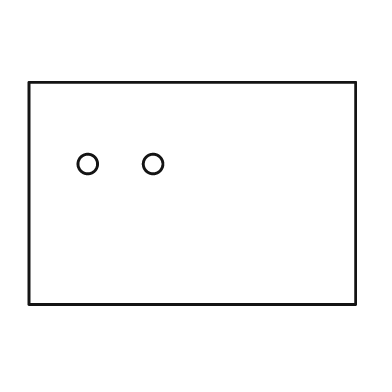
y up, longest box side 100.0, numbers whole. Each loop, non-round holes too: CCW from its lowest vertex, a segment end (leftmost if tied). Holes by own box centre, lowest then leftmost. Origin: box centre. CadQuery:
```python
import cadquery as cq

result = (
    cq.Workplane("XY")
    .moveTo(-50.0, -34.0)
    .lineTo(50.0, -34.0)
    .lineTo(50.0, 34.0)
    .lineTo(-50.0, 34.0)
    .close()
    .moveTo(-32.0, 9.0)
    .circle(3.0)
    .moveTo(-12.0, 9.0)
    .circle(3.0)
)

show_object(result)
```